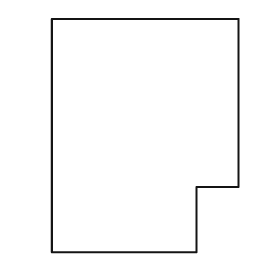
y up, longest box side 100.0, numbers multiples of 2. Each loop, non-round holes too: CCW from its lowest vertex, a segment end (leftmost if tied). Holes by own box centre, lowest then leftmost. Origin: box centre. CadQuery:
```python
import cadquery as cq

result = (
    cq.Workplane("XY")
    .moveTo(-40.0, -50.0)
    .lineTo(22.0, -50.0)
    .lineTo(22.0, -22.0)
    .lineTo(40.0, -22.0)
    .lineTo(40.0, 50.0)
    .lineTo(-40.0, 50.0)
    .close()
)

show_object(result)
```